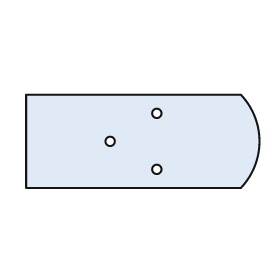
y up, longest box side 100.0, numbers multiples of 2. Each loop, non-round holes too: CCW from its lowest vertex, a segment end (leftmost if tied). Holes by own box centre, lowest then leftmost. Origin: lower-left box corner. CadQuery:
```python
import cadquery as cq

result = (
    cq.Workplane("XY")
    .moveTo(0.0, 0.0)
    .lineTo(92.0, 0.0)
    .threePointArc((100.0, 20.0), (92.0, 40.0))
    .lineTo(0.0, 40.0)
    .close()
    .moveTo(56.0, 8.0)
    .circle(2.0)
    .moveTo(36.0, 20.0)
    .circle(2.0)
    .moveTo(56.0, 32.0)
    .circle(2.0)
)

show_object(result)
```